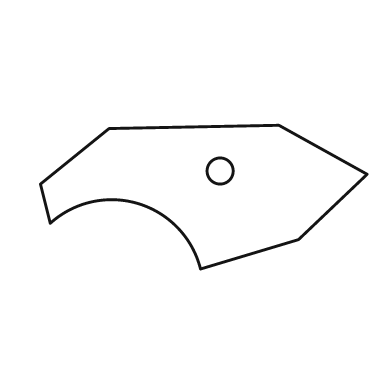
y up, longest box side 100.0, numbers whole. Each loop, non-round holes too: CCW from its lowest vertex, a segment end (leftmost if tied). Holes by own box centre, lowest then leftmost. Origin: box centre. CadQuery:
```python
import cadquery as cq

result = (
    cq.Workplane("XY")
    .moveTo(-1.0, -22.0)
    .lineTo(29.0, -13.0)
    .lineTo(50.0, 7.0)
    .lineTo(23.0, 22.0)
    .lineTo(-29.0, 21.0)
    .lineTo(-50.0, 4.0)
    .lineTo(-47.0, -8.0)
    .threePointArc((-20.0, -2.0), (-1.0, -22.0))
    .close()
    .moveTo(5.0, 8.0)
    .circle(4.0)
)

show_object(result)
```